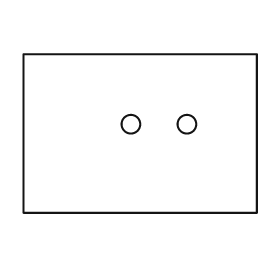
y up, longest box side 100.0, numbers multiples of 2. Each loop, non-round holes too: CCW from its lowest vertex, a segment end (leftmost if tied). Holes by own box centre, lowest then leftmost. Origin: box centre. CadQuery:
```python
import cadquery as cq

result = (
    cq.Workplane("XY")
    .moveTo(-50.0, -34.0)
    .lineTo(50.0, -34.0)
    .lineTo(50.0, 34.0)
    .lineTo(-50.0, 34.0)
    .close()
    .moveTo(-4.0, 4.0)
    .circle(4.0)
    .moveTo(20.0, 4.0)
    .circle(4.0)
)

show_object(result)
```